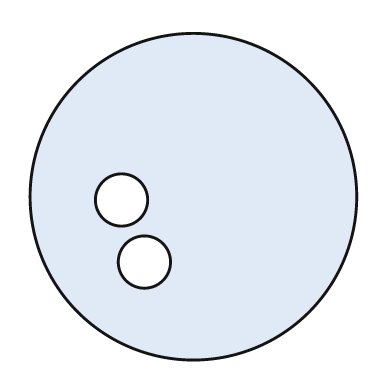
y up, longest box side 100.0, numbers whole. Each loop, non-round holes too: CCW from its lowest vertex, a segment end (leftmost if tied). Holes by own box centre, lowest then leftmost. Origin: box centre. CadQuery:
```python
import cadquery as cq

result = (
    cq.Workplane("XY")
    .moveTo(0.0, 0.0)
    .circle(50.0)
    .moveTo(-15.0, -20.0)
    .circle(8.0)
    .moveTo(-22.0, -1.0)
    .circle(8.0)
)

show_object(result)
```